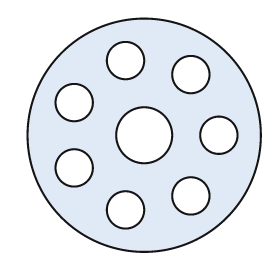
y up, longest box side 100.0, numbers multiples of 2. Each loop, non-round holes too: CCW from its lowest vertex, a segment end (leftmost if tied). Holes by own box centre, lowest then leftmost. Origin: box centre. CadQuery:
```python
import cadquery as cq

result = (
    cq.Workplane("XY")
    .moveTo(0.0, 0.0)
    .circle(50.0)
    .moveTo(-8.0, -32.0)
    .circle(8.0)
    .moveTo(20.0, -26.0)
    .circle(8.0)
    .moveTo(-30.0, -14.0)
    .circle(8.0)
    .moveTo(0.0, 0.0)
    .circle(12.0)
    .moveTo(32.0, 0.0)
    .circle(8.0)
    .moveTo(-30.0, 14.0)
    .circle(8.0)
    .moveTo(20.0, 26.0)
    .circle(8.0)
    .moveTo(-8.0, 32.0)
    .circle(8.0)
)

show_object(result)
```